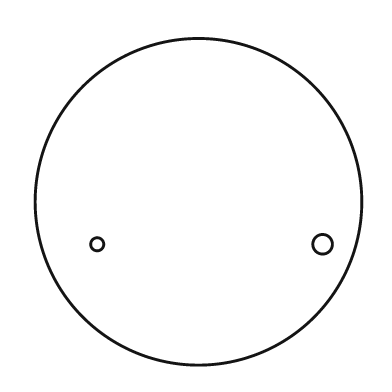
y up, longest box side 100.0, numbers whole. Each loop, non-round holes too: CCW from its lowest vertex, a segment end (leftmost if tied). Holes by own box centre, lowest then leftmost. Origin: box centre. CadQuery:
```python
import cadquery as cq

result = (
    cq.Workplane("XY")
    .moveTo(0.0, 0.0)
    .circle(50.0)
    .moveTo(-31.0, -13.0)
    .circle(2.0)
    .moveTo(38.0, -13.0)
    .circle(3.0)
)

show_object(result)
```